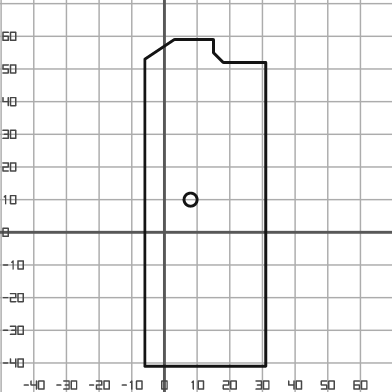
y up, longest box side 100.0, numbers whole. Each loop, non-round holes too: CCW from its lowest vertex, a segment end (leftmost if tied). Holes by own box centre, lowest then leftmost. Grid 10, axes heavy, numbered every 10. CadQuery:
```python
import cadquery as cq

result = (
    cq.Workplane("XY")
    .moveTo(-6.0, -41.0)
    .lineTo(31.0, -41.0)
    .lineTo(31.0, 52.0)
    .lineTo(18.0, 52.0)
    .lineTo(15.0, 55.0)
    .lineTo(15.0, 59.0)
    .lineTo(3.0, 59.0)
    .lineTo(-6.0, 53.0)
    .close()
    .moveTo(8.0, 10.0)
    .circle(2.0)
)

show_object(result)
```